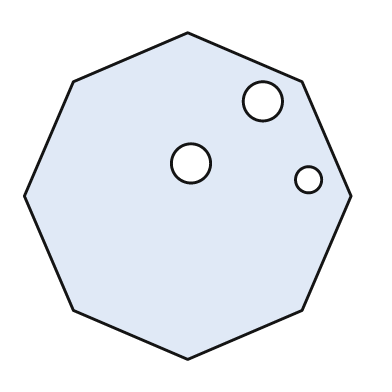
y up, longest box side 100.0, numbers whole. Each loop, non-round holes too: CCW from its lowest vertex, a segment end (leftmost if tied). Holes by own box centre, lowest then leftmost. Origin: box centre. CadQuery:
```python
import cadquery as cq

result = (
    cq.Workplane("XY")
    .moveTo(0.0, -50.0)
    .lineTo(35.0, -35.0)
    .lineTo(50.0, 0.0)
    .lineTo(35.0, 35.0)
    .lineTo(0.0, 50.0)
    .lineTo(-35.0, 35.0)
    .lineTo(-50.0, 0.0)
    .lineTo(-35.0, -35.0)
    .close()
    .moveTo(37.0, 5.0)
    .circle(4.0)
    .moveTo(1.0, 10.0)
    .circle(6.0)
    .moveTo(23.0, 29.0)
    .circle(6.0)
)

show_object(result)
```